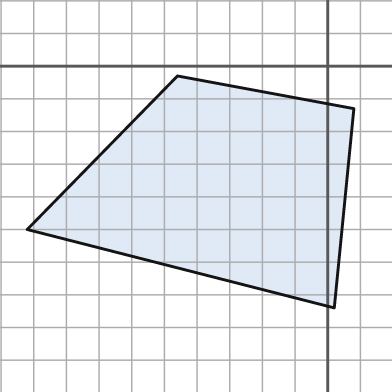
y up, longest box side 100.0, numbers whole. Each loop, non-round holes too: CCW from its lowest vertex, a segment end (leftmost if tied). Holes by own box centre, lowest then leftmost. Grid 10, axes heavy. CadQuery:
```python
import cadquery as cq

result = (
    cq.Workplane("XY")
    .moveTo(2.0, -74.0)
    .lineTo(8.0, -13.0)
    .lineTo(-46.0, -3.0)
    .lineTo(-92.0, -50.0)
    .close()
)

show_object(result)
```